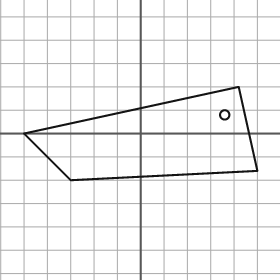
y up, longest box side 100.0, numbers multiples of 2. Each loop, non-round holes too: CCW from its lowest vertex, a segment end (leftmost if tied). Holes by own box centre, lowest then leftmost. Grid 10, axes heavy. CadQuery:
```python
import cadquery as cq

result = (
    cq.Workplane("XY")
    .moveTo(-30.0, -20.0)
    .lineTo(50.0, -16.0)
    .lineTo(42.0, 20.0)
    .lineTo(-50.0, 0.0)
    .close()
    .moveTo(36.0, 8.0)
    .circle(2.0)
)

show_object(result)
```